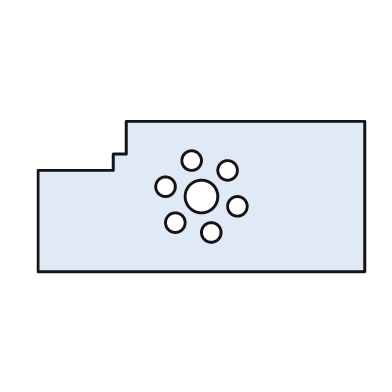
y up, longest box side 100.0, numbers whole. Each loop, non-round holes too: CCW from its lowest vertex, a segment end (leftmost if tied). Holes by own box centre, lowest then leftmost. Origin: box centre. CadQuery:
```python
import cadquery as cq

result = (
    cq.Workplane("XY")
    .moveTo(-50.0, -23.0)
    .lineTo(50.0, -23.0)
    .lineTo(50.0, 23.0)
    .lineTo(-23.0, 23.0)
    .lineTo(-23.0, 13.0)
    .lineTo(-27.0, 13.0)
    .lineTo(-27.0, 8.0)
    .lineTo(-50.0, 8.0)
    .close()
    .moveTo(3.0, -11.0)
    .circle(3.0)
    .moveTo(-8.0, -8.0)
    .circle(3.0)
    .moveTo(11.0, -3.0)
    .circle(3.0)
    .moveTo(0.0, 0.0)
    .circle(5.0)
    .moveTo(-11.0, 3.0)
    .circle(3.0)
    .moveTo(8.0, 8.0)
    .circle(3.0)
    .moveTo(-3.0, 11.0)
    .circle(3.0)
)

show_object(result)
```